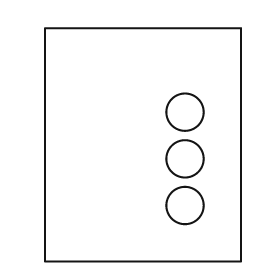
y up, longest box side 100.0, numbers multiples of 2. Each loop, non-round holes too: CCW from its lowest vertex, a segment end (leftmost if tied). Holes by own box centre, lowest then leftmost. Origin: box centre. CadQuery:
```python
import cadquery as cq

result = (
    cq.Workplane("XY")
    .moveTo(-42.0, -50.0)
    .lineTo(42.0, -50.0)
    .lineTo(42.0, 50.0)
    .lineTo(-42.0, 50.0)
    .close()
    .moveTo(18.0, -26.0)
    .circle(8.0)
    .moveTo(18.0, -6.0)
    .circle(8.0)
    .moveTo(18.0, 14.0)
    .circle(8.0)
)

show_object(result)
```